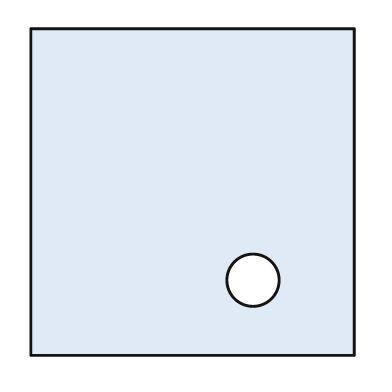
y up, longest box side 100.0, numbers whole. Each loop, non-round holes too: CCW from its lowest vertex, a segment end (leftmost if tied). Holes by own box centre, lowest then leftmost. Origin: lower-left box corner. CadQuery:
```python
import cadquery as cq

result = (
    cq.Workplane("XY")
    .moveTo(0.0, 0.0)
    .lineTo(99.0, 0.0)
    .lineTo(99.0, 100.0)
    .lineTo(0.0, 100.0)
    .close()
    .moveTo(68.0, 23.0)
    .circle(8.0)
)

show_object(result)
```